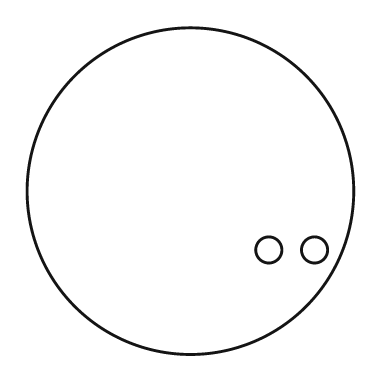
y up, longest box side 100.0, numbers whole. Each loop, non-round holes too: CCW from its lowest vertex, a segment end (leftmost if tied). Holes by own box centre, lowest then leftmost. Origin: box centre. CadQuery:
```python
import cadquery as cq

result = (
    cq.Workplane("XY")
    .moveTo(0.0, 0.0)
    .circle(50.0)
    .moveTo(24.0, -18.0)
    .circle(4.0)
    .moveTo(38.0, -18.0)
    .circle(4.0)
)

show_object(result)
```